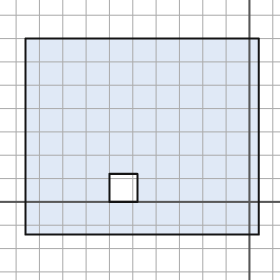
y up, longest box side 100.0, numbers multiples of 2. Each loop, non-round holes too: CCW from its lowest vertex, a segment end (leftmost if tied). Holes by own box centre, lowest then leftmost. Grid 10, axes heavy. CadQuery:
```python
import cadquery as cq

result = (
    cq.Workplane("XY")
    .moveTo(-96.0, -14.0)
    .lineTo(4.0, -14.0)
    .lineTo(4.0, 70.0)
    .lineTo(-96.0, 70.0)
    .close()
    .moveTo(-60.0, 0.0)
    .lineTo(-48.0, 0.0)
    .lineTo(-48.0, 12.0)
    .lineTo(-60.0, 12.0)
    .close()
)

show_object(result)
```